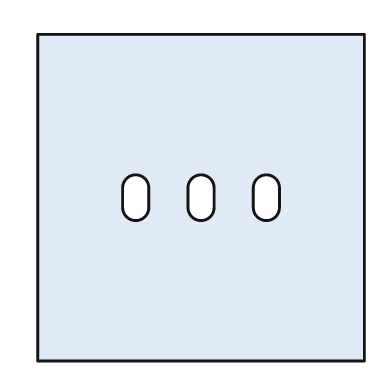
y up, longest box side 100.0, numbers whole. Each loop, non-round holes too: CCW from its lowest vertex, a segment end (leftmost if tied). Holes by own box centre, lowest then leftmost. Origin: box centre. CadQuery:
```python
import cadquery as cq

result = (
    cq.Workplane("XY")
    .moveTo(-50.0, -50.0)
    .lineTo(50.0, -50.0)
    .lineTo(50.0, 50.0)
    .lineTo(-50.0, 50.0)
    .close()
    .moveTo(-24.0, -3.0)
    .threePointArc((-20.0, -7.0), (-16.0, -3.0))
    .lineTo(-16.0, 3.0)
    .threePointArc((-20.0, 7.0), (-24.0, 3.0))
    .close()
    .moveTo(-4.0, -3.0)
    .threePointArc((0.0, -7.0), (4.0, -3.0))
    .lineTo(4.0, 3.0)
    .threePointArc((0.0, 7.0), (-4.0, 3.0))
    .close()
    .moveTo(16.0, -3.0)
    .threePointArc((20.0, -7.0), (24.0, -3.0))
    .lineTo(24.0, 3.0)
    .threePointArc((20.0, 7.0), (16.0, 3.0))
    .close()
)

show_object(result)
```